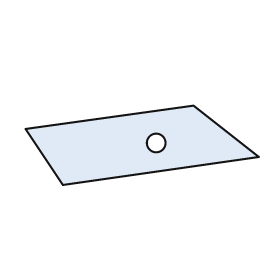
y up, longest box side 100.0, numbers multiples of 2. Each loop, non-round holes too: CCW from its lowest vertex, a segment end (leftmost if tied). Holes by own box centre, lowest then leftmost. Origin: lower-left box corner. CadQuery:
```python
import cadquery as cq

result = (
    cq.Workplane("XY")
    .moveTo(16.0, 0.0)
    .lineTo(100.0, 12.0)
    .lineTo(72.0, 34.0)
    .lineTo(0.0, 24.0)
    .close()
    .moveTo(56.0, 18.0)
    .circle(4.0)
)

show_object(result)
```